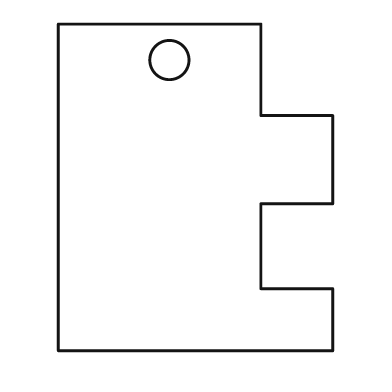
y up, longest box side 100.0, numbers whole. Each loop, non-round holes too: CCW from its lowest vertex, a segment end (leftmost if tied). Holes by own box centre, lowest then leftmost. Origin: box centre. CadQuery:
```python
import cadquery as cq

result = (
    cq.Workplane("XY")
    .moveTo(-42.0, -50.0)
    .lineTo(42.0, -50.0)
    .lineTo(42.0, -31.0)
    .lineTo(20.0, -31.0)
    .lineTo(20.0, -5.0)
    .lineTo(42.0, -5.0)
    .lineTo(42.0, 22.0)
    .lineTo(20.0, 22.0)
    .lineTo(20.0, 50.0)
    .lineTo(-42.0, 50.0)
    .close()
    .moveTo(-8.0, 39.0)
    .circle(6.0)
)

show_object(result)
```